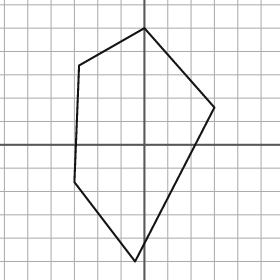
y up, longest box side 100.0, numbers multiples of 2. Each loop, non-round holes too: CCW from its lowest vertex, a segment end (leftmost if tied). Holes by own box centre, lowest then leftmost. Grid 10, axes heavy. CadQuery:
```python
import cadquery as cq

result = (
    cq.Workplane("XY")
    .moveTo(-4.0, -50.0)
    .lineTo(30.0, 16.0)
    .lineTo(0.0, 50.0)
    .lineTo(-28.0, 34.0)
    .lineTo(-30.0, -16.0)
    .close()
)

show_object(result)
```